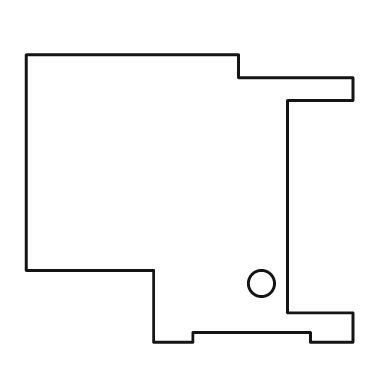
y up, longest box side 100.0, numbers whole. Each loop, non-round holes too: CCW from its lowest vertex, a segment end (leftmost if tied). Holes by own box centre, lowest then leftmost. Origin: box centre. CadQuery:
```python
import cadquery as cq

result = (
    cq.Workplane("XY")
    .moveTo(-11.0, -44.0)
    .lineTo(1.0, -44.0)
    .lineTo(1.0, -41.0)
    .lineTo(37.0, -41.0)
    .lineTo(37.0, -44.0)
    .lineTo(50.0, -44.0)
    .lineTo(50.0, -35.0)
    .lineTo(30.0, -35.0)
    .lineTo(30.0, 30.0)
    .lineTo(50.0, 30.0)
    .lineTo(50.0, 37.0)
    .lineTo(15.0, 37.0)
    .lineTo(15.0, 44.0)
    .lineTo(-50.0, 44.0)
    .lineTo(-50.0, -22.0)
    .lineTo(-11.0, -22.0)
    .close()
    .moveTo(22.0, -26.0)
    .circle(4.0)
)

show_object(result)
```